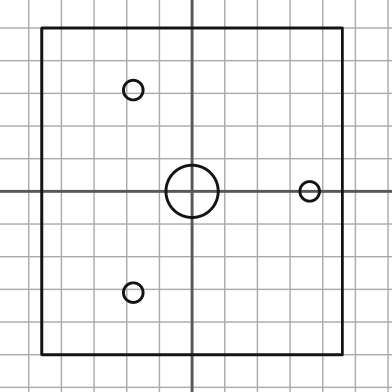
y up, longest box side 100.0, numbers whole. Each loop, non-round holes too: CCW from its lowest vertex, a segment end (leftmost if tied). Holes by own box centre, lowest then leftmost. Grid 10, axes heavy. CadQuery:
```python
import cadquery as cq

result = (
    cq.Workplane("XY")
    .moveTo(-46.0, -50.0)
    .lineTo(46.0, -50.0)
    .lineTo(46.0, 50.0)
    .lineTo(-46.0, 50.0)
    .close()
    .moveTo(-18.0, -31.0)
    .circle(3.0)
    .moveTo(0.0, 0.0)
    .circle(8.0)
    .moveTo(36.0, 0.0)
    .circle(3.0)
    .moveTo(-18.0, 31.0)
    .circle(3.0)
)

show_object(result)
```